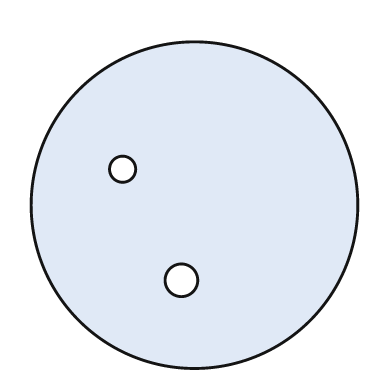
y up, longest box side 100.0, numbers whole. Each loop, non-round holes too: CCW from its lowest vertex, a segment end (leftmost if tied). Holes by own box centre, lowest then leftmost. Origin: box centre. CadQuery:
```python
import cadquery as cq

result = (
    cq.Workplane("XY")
    .moveTo(0.0, 0.0)
    .circle(50.0)
    .moveTo(-4.0, -23.0)
    .circle(5.0)
    .moveTo(-22.0, 11.0)
    .circle(4.0)
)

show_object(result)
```